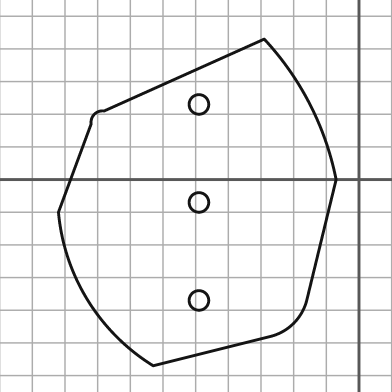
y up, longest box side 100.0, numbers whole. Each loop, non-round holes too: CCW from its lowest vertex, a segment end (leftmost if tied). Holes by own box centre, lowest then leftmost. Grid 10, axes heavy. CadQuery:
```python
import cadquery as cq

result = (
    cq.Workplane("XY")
    .moveTo(-63.0, -57.0)
    .lineTo(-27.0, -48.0)
    .threePointArc((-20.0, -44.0), (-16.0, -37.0))
    .lineTo(-7.0, 0.0)
    .threePointArc((-15.0, 23.0), (-29.0, 43.0))
    .lineTo(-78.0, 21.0)
    .threePointArc((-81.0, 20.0), (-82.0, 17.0))
    .lineTo(-92.0, -10.0)
    .threePointArc((-83.0, -37.0), (-63.0, -57.0))
    .close()
    .moveTo(-49.0, -37.0)
    .circle(3.0)
    .moveTo(-49.0, -7.0)
    .circle(3.0)
    .moveTo(-49.0, 23.0)
    .circle(3.0)
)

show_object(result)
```